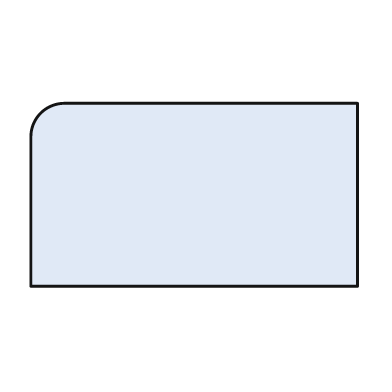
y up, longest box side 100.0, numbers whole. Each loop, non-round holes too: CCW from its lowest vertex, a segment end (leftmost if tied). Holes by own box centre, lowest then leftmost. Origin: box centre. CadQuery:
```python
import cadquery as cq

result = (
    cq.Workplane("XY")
    .moveTo(-50.0, -28.0)
    .lineTo(50.0, -28.0)
    .lineTo(50.0, 28.0)
    .lineTo(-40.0, 28.0)
    .threePointArc((-47.0, 25.0), (-50.0, 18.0))
    .close()
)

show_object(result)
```